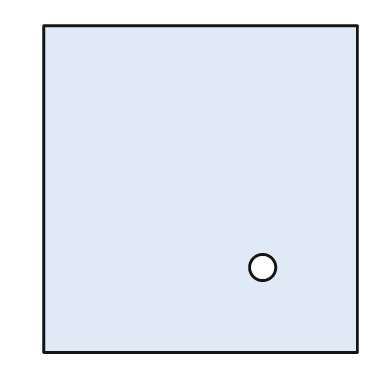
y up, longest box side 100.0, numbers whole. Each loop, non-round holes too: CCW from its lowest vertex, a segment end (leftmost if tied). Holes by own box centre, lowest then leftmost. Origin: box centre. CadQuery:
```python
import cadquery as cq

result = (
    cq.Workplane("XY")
    .moveTo(-48.0, -50.0)
    .lineTo(48.0, -50.0)
    .lineTo(48.0, 50.0)
    .lineTo(-48.0, 50.0)
    .close()
    .moveTo(19.0, -24.0)
    .circle(4.0)
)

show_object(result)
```